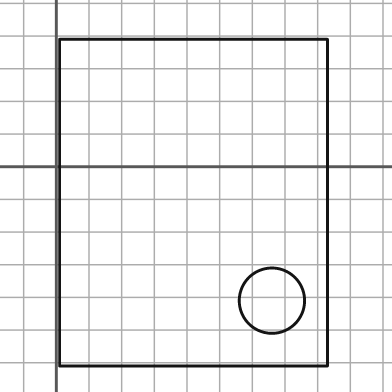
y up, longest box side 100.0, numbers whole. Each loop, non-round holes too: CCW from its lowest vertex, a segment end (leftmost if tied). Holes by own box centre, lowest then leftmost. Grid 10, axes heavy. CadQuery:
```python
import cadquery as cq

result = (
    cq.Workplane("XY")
    .moveTo(1.0, -61.0)
    .lineTo(83.0, -61.0)
    .lineTo(83.0, 39.0)
    .lineTo(1.0, 39.0)
    .close()
    .moveTo(66.0, -41.0)
    .circle(10.0)
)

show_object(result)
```